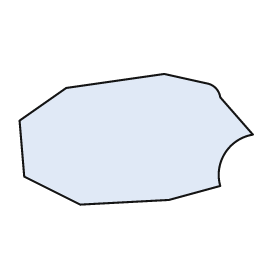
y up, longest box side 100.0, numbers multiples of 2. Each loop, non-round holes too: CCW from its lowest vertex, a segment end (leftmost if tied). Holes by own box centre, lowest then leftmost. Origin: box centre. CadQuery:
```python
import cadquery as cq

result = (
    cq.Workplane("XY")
    .moveTo(-24.0, -28.0)
    .lineTo(14.0, -26.0)
    .lineTo(36.0, -20.0)
    .threePointArc((38.0, -6.0), (50.0, 2.0))
    .lineTo(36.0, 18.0)
    .threePointArc((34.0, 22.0), (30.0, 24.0))
    .lineTo(12.0, 28.0)
    .lineTo(-30.0, 22.0)
    .lineTo(-50.0, 8.0)
    .lineTo(-48.0, -16.0)
    .close()
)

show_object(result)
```